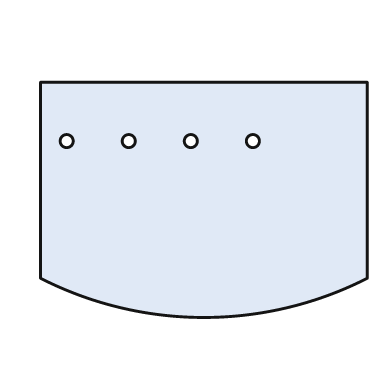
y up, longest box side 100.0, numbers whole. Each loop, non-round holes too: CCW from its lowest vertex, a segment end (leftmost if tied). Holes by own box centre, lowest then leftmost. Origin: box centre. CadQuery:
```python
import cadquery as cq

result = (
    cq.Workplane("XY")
    .moveTo(-50.0, -24.0)
    .threePointArc((0.0, -36.0), (50.0, -24.0))
    .lineTo(50.0, 36.0)
    .lineTo(-50.0, 36.0)
    .close()
    .moveTo(-42.0, 18.0)
    .circle(2.0)
    .moveTo(-23.0, 18.0)
    .circle(2.0)
    .moveTo(-4.0, 18.0)
    .circle(2.0)
    .moveTo(15.0, 18.0)
    .circle(2.0)
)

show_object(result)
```